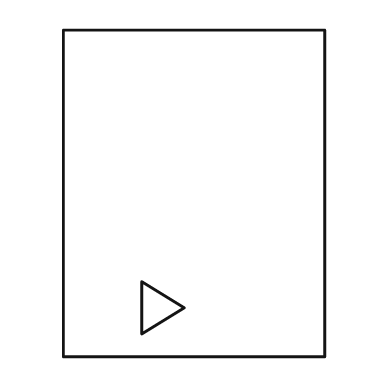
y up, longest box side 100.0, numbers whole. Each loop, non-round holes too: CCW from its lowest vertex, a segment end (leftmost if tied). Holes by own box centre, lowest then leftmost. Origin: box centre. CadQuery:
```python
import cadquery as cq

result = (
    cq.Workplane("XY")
    .moveTo(-40.0, -50.0)
    .lineTo(40.0, -50.0)
    .lineTo(40.0, 50.0)
    .lineTo(-40.0, 50.0)
    .close()
    .moveTo(-16.0, -43.0)
    .lineTo(-3.0, -35.0)
    .lineTo(-16.0, -27.0)
    .close()
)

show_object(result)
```